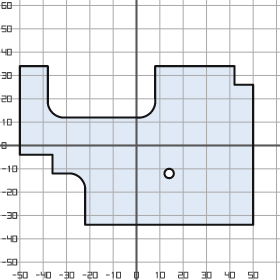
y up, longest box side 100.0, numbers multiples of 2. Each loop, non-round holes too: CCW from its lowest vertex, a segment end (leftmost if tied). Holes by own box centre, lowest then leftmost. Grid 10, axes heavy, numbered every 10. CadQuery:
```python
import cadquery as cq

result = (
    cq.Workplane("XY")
    .moveTo(-22.0, -34.0)
    .lineTo(50.0, -34.0)
    .lineTo(50.0, 26.0)
    .lineTo(42.0, 26.0)
    .lineTo(42.0, 34.0)
    .lineTo(8.0, 34.0)
    .lineTo(8.0, 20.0)
    .threePointArc((6.0, 14.0), (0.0, 12.0))
    .lineTo(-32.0, 12.0)
    .threePointArc((-36.0, 14.0), (-38.0, 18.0))
    .lineTo(-38.0, 34.0)
    .lineTo(-50.0, 34.0)
    .lineTo(-50.0, -4.0)
    .lineTo(-36.0, -4.0)
    .lineTo(-36.0, -12.0)
    .lineTo(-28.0, -12.0)
    .threePointArc((-24.0, -14.0), (-22.0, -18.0))
    .close()
    .moveTo(14.0, -12.0)
    .circle(2.0)
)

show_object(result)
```